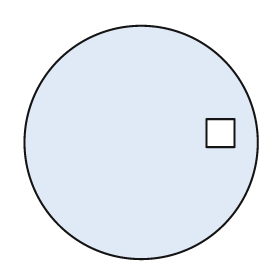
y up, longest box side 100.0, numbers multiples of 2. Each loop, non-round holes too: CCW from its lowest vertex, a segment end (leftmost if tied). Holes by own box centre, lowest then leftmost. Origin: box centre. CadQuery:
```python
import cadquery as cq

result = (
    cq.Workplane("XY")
    .moveTo(0.0, 0.0)
    .circle(50.0)
    .moveTo(28.0, -2.0)
    .lineTo(40.0, -2.0)
    .lineTo(40.0, 10.0)
    .lineTo(28.0, 10.0)
    .close()
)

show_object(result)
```